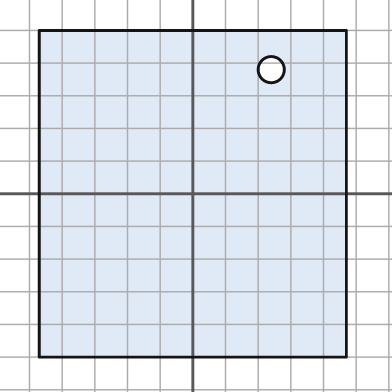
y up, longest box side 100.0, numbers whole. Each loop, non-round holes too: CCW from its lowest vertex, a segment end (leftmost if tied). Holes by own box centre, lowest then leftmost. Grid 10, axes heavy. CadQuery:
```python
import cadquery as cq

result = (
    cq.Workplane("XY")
    .moveTo(-47.0, -50.0)
    .lineTo(47.0, -50.0)
    .lineTo(47.0, 50.0)
    .lineTo(-47.0, 50.0)
    .close()
    .moveTo(24.0, 38.0)
    .circle(4.0)
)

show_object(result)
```